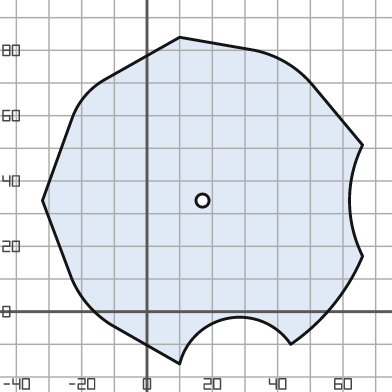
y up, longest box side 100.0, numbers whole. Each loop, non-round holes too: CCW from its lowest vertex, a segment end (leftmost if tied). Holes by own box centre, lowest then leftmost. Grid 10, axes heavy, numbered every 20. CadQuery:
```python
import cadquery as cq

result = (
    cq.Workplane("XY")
    .moveTo(10.0, -16.0)
    .threePointArc((25.0, -2.0), (44.0, -10.0))
    .threePointArc((57.0, 2.0), (66.0, 17.0))
    .threePointArc((62.0, 34.0), (66.0, 51.0))
    .lineTo(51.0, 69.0)
    .threePointArc((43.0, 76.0), (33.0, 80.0))
    .lineTo(10.0, 84.0)
    .lineTo(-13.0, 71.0)
    .threePointArc((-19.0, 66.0), (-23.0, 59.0))
    .lineTo(-32.0, 34.0)
    .lineTo(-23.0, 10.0)
    .threePointArc((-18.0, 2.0), (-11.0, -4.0))
    .close()
    .moveTo(17.0, 34.0)
    .circle(2.0)
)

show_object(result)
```